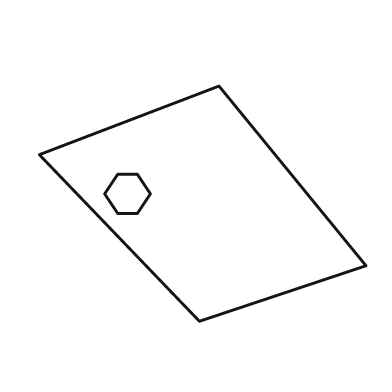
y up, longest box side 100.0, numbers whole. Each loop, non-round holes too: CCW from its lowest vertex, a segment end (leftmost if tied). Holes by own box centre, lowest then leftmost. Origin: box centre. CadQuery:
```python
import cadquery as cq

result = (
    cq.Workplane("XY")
    .moveTo(-1.0, -36.0)
    .lineTo(50.0, -19.0)
    .lineTo(5.0, 36.0)
    .lineTo(-50.0, 15.0)
    .close()
    .moveTo(-26.0, -3.0)
    .lineTo(-20.0, -3.0)
    .lineTo(-16.0, 3.0)
    .lineTo(-20.0, 9.0)
    .lineTo(-26.0, 9.0)
    .lineTo(-30.0, 3.0)
    .close()
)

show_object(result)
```